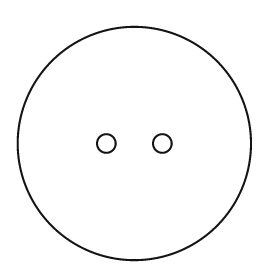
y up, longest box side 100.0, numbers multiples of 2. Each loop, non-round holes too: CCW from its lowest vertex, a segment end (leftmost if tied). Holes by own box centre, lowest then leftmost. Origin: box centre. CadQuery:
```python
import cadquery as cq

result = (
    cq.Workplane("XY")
    .moveTo(0.0, 0.0)
    .circle(50.0)
    .moveTo(-12.0, 0.0)
    .circle(4.0)
    .moveTo(12.0, 0.0)
    .circle(4.0)
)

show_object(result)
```